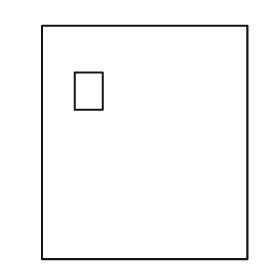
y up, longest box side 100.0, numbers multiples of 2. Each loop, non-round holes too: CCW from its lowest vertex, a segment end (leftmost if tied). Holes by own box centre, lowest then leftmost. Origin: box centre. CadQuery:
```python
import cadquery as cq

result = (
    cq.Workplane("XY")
    .moveTo(-44.0, -50.0)
    .lineTo(44.0, -50.0)
    .lineTo(44.0, 50.0)
    .lineTo(-44.0, 50.0)
    .close()
    .moveTo(-30.0, 14.0)
    .lineTo(-18.0, 14.0)
    .lineTo(-18.0, 30.0)
    .lineTo(-30.0, 30.0)
    .close()
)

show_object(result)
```